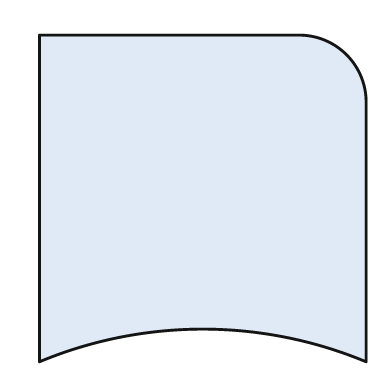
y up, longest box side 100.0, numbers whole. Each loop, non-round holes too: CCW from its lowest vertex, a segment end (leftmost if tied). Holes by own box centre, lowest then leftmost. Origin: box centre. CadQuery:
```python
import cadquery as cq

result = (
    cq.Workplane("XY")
    .moveTo(-50.0, -50.0)
    .threePointArc((0.0, -40.0), (50.0, -50.0))
    .lineTo(50.0, 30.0)
    .threePointArc((44.0, 44.0), (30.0, 50.0))
    .lineTo(-50.0, 50.0)
    .close()
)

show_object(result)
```